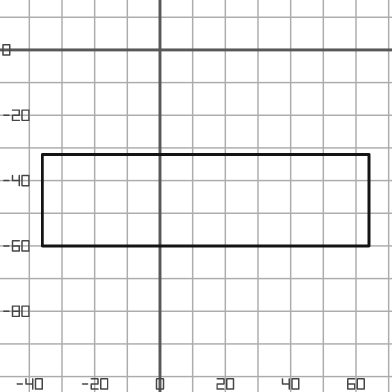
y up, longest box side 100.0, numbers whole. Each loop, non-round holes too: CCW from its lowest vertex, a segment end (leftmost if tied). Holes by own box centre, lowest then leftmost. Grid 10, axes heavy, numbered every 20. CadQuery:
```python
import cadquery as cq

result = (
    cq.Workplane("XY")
    .moveTo(-36.0, -60.0)
    .lineTo(64.0, -60.0)
    .lineTo(64.0, -32.0)
    .lineTo(-36.0, -32.0)
    .close()
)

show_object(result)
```